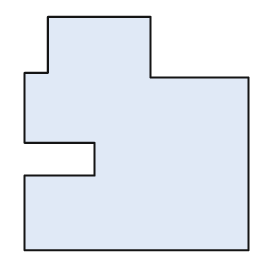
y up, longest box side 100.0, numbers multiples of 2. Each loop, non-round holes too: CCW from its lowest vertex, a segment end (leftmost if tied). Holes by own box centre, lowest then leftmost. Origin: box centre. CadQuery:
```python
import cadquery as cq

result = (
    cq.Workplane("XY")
    .moveTo(-48.0, -50.0)
    .lineTo(48.0, -50.0)
    .lineTo(48.0, 24.0)
    .lineTo(6.0, 24.0)
    .lineTo(6.0, 50.0)
    .lineTo(-38.0, 50.0)
    .lineTo(-38.0, 26.0)
    .lineTo(-48.0, 26.0)
    .lineTo(-48.0, -4.0)
    .lineTo(-18.0, -4.0)
    .lineTo(-18.0, -18.0)
    .lineTo(-48.0, -18.0)
    .close()
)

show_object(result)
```